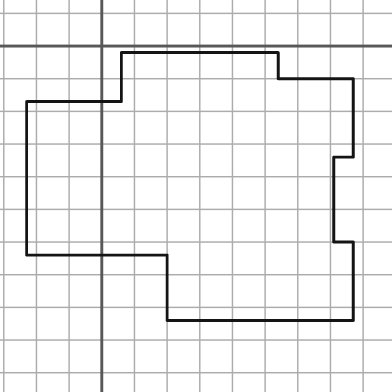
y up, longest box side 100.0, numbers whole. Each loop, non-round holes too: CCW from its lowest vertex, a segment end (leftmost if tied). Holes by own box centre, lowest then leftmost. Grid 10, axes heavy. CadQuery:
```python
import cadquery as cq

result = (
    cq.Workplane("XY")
    .moveTo(20.0, -84.0)
    .lineTo(77.0, -84.0)
    .lineTo(77.0, -60.0)
    .lineTo(71.0, -60.0)
    .lineTo(71.0, -34.0)
    .lineTo(77.0, -34.0)
    .lineTo(77.0, -10.0)
    .lineTo(54.0, -10.0)
    .lineTo(54.0, -2.0)
    .lineTo(6.0, -2.0)
    .lineTo(6.0, -17.0)
    .lineTo(-23.0, -17.0)
    .lineTo(-23.0, -64.0)
    .lineTo(20.0, -64.0)
    .close()
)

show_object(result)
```